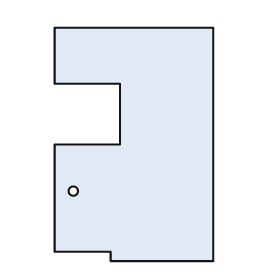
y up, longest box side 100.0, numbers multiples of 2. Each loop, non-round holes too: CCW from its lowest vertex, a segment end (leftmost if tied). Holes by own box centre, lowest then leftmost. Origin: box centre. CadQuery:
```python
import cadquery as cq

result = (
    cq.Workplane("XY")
    .moveTo(-10.0, -50.0)
    .lineTo(34.0, -50.0)
    .lineTo(34.0, 50.0)
    .lineTo(-34.0, 50.0)
    .lineTo(-34.0, 26.0)
    .lineTo(-6.0, 26.0)
    .lineTo(-6.0, 0.0)
    .lineTo(-34.0, 0.0)
    .lineTo(-34.0, -46.0)
    .lineTo(-10.0, -46.0)
    .close()
    .moveTo(-26.0, -20.0)
    .circle(2.0)
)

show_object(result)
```